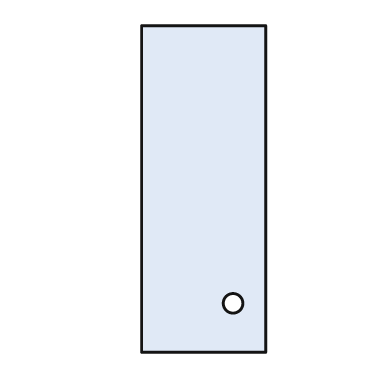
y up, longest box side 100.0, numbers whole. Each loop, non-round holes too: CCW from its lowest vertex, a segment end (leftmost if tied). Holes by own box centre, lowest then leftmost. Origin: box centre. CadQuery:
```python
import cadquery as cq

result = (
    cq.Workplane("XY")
    .moveTo(-19.0, -50.0)
    .lineTo(19.0, -50.0)
    .lineTo(19.0, 50.0)
    .lineTo(-19.0, 50.0)
    .close()
    .moveTo(9.0, -35.0)
    .circle(3.0)
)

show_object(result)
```